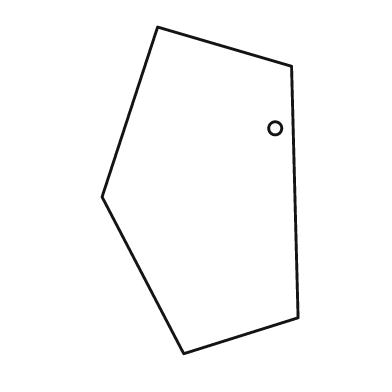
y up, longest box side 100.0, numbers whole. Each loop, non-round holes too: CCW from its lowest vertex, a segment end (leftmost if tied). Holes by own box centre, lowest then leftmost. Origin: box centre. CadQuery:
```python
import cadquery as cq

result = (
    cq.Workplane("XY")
    .moveTo(-5.0, -50.0)
    .lineTo(30.0, -39.0)
    .lineTo(28.0, 38.0)
    .lineTo(-13.0, 50.0)
    .lineTo(-30.0, -2.0)
    .close()
    .moveTo(23.0, 19.0)
    .circle(2.0)
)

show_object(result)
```